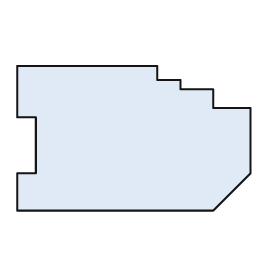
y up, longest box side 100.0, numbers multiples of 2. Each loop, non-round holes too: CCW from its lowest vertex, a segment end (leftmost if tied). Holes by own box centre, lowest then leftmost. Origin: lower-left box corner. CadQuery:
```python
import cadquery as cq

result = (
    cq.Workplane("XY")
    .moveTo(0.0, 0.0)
    .lineTo(84.0, 0.0)
    .lineTo(100.0, 16.0)
    .lineTo(100.0, 44.0)
    .lineTo(84.0, 44.0)
    .lineTo(84.0, 52.0)
    .lineTo(70.0, 52.0)
    .lineTo(70.0, 56.0)
    .lineTo(60.0, 56.0)
    .lineTo(60.0, 62.0)
    .lineTo(0.0, 62.0)
    .lineTo(0.0, 40.0)
    .lineTo(8.0, 40.0)
    .lineTo(8.0, 16.0)
    .lineTo(0.0, 16.0)
    .close()
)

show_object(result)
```